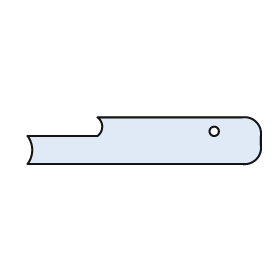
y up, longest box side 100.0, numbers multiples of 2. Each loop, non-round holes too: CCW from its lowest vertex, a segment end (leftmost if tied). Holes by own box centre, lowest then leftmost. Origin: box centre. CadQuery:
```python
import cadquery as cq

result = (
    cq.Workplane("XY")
    .moveTo(-50.0, -10.0)
    .lineTo(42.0, -10.0)
    .threePointArc((48.0, -8.0), (50.0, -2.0))
    .lineTo(50.0, 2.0)
    .threePointArc((48.0, 8.0), (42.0, 10.0))
    .lineTo(-20.0, 10.0)
    .threePointArc((-18.0, 6.0), (-20.0, 2.0))
    .lineTo(-50.0, 2.0)
    .threePointArc((-48.0, -4.0), (-50.0, -10.0))
    .close()
    .moveTo(30.0, 4.0)
    .circle(2.0)
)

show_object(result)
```